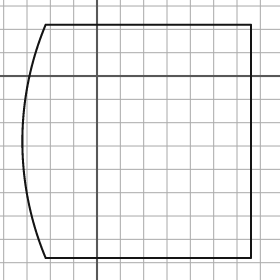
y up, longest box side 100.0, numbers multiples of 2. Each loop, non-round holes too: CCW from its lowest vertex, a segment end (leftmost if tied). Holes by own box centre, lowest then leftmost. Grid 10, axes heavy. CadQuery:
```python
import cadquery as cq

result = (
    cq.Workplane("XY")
    .moveTo(-22.0, -78.0)
    .lineTo(66.0, -78.0)
    .lineTo(66.0, 22.0)
    .lineTo(-22.0, 22.0)
    .threePointArc((-32.0, -28.0), (-22.0, -78.0))
    .close()
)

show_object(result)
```